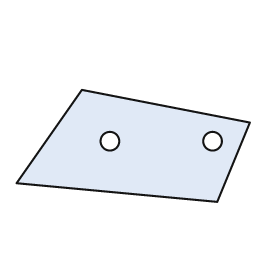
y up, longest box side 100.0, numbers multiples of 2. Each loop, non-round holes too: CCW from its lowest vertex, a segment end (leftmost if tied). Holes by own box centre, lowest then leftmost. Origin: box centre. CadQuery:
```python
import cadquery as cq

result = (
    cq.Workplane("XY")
    .moveTo(36.0, -24.0)
    .lineTo(50.0, 10.0)
    .lineTo(-22.0, 24.0)
    .lineTo(-50.0, -16.0)
    .close()
    .moveTo(-10.0, 2.0)
    .circle(4.0)
    .moveTo(34.0, 2.0)
    .circle(4.0)
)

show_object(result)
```